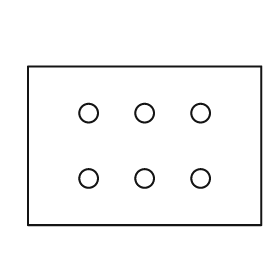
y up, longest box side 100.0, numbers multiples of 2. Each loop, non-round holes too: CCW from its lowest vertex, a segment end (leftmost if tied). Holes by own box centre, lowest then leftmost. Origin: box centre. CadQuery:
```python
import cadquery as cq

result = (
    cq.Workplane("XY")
    .moveTo(-50.0, -34.0)
    .lineTo(50.0, -34.0)
    .lineTo(50.0, 34.0)
    .lineTo(-50.0, 34.0)
    .close()
    .moveTo(-24.0, -14.0)
    .circle(4.0)
    .moveTo(0.0, -14.0)
    .circle(4.0)
    .moveTo(24.0, -14.0)
    .circle(4.0)
    .moveTo(-24.0, 14.0)
    .circle(4.0)
    .moveTo(0.0, 14.0)
    .circle(4.0)
    .moveTo(24.0, 14.0)
    .circle(4.0)
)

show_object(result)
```